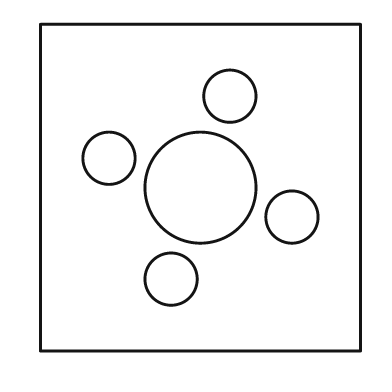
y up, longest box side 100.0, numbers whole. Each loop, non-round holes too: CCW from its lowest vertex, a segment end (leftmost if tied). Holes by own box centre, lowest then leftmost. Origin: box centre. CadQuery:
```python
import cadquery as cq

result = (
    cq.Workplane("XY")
    .moveTo(-49.0, -50.0)
    .lineTo(49.0, -50.0)
    .lineTo(49.0, 50.0)
    .lineTo(-49.0, 50.0)
    .close()
    .moveTo(-9.0, -28.0)
    .circle(8.0)
    .moveTo(28.0, -9.0)
    .circle(8.0)
    .moveTo(0.0, 0.0)
    .circle(17.0)
    .moveTo(-28.0, 9.0)
    .circle(8.0)
    .moveTo(9.0, 28.0)
    .circle(8.0)
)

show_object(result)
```